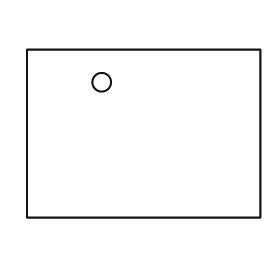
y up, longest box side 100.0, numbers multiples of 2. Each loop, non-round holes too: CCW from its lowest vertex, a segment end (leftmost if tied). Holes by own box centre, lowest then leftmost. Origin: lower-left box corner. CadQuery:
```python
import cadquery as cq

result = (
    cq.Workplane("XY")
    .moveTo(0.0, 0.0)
    .lineTo(100.0, 0.0)
    .lineTo(100.0, 72.0)
    .lineTo(0.0, 72.0)
    .close()
    .moveTo(32.0, 58.0)
    .circle(4.0)
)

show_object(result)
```